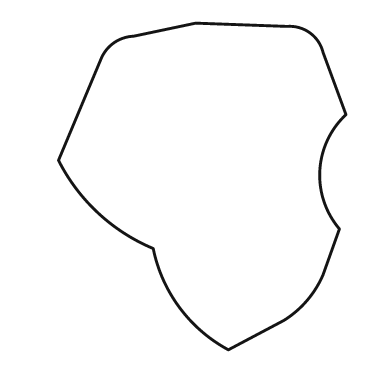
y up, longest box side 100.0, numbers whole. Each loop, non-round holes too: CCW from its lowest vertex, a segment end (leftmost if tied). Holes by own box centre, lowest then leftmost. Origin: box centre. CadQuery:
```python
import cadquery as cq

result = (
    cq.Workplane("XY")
    .moveTo(8.0, -50.0)
    .lineTo(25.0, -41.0)
    .threePointArc((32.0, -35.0), (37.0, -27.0))
    .lineTo(42.0, -13.0)
    .threePointArc((36.0, 5.0), (44.0, 22.0))
    .lineTo(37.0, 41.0)
    .threePointArc((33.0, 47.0), (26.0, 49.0))
    .lineTo(-2.0, 50.0)
    .lineTo(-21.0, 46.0)
    .threePointArc((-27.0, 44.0), (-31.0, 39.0))
    .lineTo(-44.0, 8.0)
    .threePointArc((-32.0, -8.0), (-15.0, -19.0))
    .threePointArc((-7.0, -37.0), (8.0, -50.0))
    .close()
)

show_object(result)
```